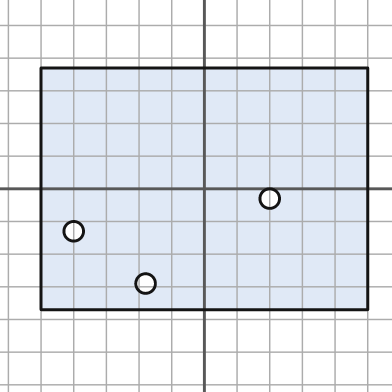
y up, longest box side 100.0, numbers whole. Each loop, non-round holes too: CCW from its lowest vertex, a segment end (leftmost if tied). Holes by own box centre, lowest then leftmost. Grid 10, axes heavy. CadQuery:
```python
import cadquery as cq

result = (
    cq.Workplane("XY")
    .moveTo(-50.0, -37.0)
    .lineTo(50.0, -37.0)
    .lineTo(50.0, 37.0)
    .lineTo(-50.0, 37.0)
    .close()
    .moveTo(-18.0, -29.0)
    .circle(3.0)
    .moveTo(-40.0, -13.0)
    .circle(3.0)
    .moveTo(20.0, -3.0)
    .circle(3.0)
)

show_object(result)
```